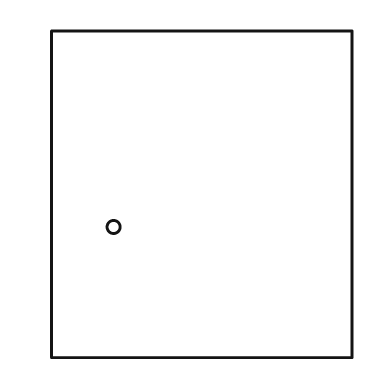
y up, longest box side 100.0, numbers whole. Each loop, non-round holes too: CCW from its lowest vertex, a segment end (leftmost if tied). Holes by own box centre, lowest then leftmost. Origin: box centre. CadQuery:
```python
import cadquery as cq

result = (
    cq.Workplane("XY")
    .moveTo(-46.0, -50.0)
    .lineTo(46.0, -50.0)
    .lineTo(46.0, 50.0)
    .lineTo(-46.0, 50.0)
    .close()
    .moveTo(-27.0, -10.0)
    .circle(2.0)
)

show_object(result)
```